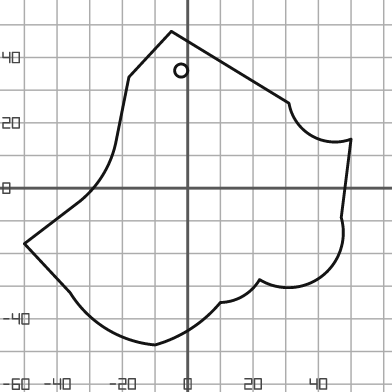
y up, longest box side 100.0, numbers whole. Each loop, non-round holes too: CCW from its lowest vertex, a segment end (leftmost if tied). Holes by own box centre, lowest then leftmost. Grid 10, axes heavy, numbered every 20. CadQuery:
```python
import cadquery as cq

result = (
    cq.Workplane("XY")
    .moveTo(-10.0, -48.0)
    .threePointArc((1.0, -43.0), (10.0, -35.0))
    .threePointArc((17.0, -33.0), (22.0, -28.0))
    .threePointArc((41.0, -27.0), (47.0, -9.0))
    .lineTo(50.0, 15.0)
    .threePointArc((38.0, 16.0), (31.0, 26.0))
    .lineTo(-5.0, 48.0)
    .lineTo(-18.0, 34.0)
    .lineTo(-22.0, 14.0)
    .threePointArc((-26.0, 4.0), (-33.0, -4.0))
    .lineTo(-50.0, -17.0)
    .lineTo(-36.0, -32.0)
    .threePointArc((-25.0, -43.0), (-10.0, -48.0))
    .close()
    .moveTo(-2.0, 36.0)
    .circle(2.0)
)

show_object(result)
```